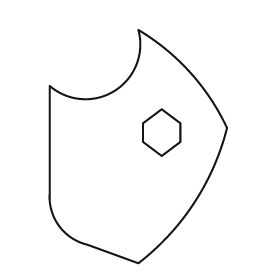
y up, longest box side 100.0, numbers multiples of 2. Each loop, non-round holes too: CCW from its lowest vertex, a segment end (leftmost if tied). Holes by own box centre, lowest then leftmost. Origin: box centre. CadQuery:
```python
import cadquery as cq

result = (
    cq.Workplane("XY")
    .moveTo(0.0, -50.0)
    .threePointArc((24.0, -24.0), (38.0, 8.0))
    .threePointArc((22.0, 32.0), (0.0, 50.0))
    .threePointArc((-10.0, 24.0), (-38.0, 26.0))
    .lineTo(-38.0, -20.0)
    .threePointArc((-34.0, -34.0), (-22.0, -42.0))
    .close()
    .moveTo(10.0, -4.0)
    .lineTo(18.0, 2.0)
    .lineTo(18.0, 10.0)
    .lineTo(10.0, 16.0)
    .lineTo(2.0, 10.0)
    .lineTo(2.0, 2.0)
    .close()
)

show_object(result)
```